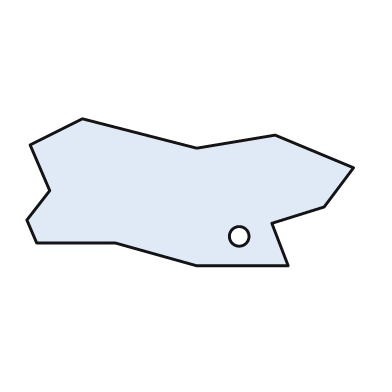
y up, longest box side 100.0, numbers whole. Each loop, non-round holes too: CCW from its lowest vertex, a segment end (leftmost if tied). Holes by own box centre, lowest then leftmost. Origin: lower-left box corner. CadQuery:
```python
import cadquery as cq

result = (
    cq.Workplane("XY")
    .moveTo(52.0, 0.0)
    .lineTo(80.0, 0.0)
    .lineTo(75.0, 13.0)
    .lineTo(91.0, 18.0)
    .lineTo(100.0, 30.0)
    .lineTo(76.0, 40.0)
    .lineTo(52.0, 36.0)
    .lineTo(17.0, 45.0)
    .lineTo(1.0, 37.0)
    .lineTo(7.0, 23.0)
    .lineTo(0.0, 14.0)
    .lineTo(3.0, 7.0)
    .lineTo(27.0, 7.0)
    .close()
    .moveTo(65.0, 9.0)
    .circle(3.0)
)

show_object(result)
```